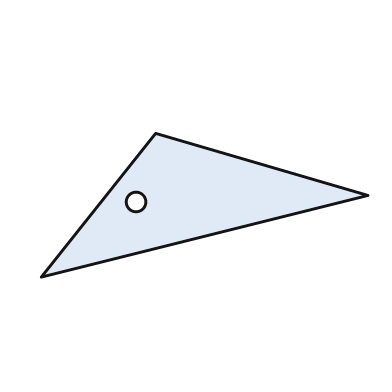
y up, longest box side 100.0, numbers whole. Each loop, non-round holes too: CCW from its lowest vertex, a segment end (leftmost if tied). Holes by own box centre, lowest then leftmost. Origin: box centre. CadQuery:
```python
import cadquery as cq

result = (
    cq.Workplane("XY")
    .moveTo(-50.0, -22.0)
    .lineTo(50.0, 3.0)
    .lineTo(-15.0, 22.0)
    .close()
    .moveTo(-21.0, 1.0)
    .circle(3.0)
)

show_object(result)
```